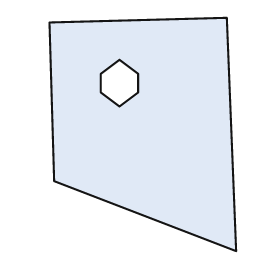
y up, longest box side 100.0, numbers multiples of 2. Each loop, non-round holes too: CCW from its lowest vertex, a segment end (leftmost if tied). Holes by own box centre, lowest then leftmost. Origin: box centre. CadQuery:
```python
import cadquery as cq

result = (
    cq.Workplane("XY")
    .moveTo(40.0, -50.0)
    .lineTo(36.0, 50.0)
    .lineTo(-40.0, 48.0)
    .lineTo(-38.0, -20.0)
    .close()
    .moveTo(-10.0, 12.0)
    .lineTo(-2.0, 18.0)
    .lineTo(-2.0, 26.0)
    .lineTo(-10.0, 32.0)
    .lineTo(-18.0, 26.0)
    .lineTo(-18.0, 18.0)
    .close()
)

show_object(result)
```